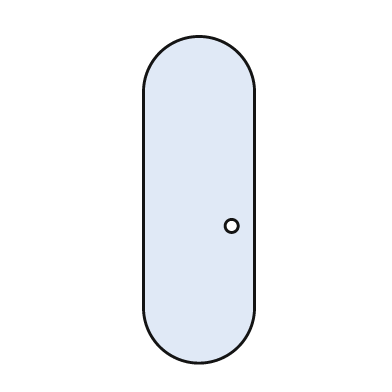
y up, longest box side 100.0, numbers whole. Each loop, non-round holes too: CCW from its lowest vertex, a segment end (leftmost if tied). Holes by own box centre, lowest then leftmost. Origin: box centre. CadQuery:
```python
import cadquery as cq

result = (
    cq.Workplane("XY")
    .moveTo(-17.0, -33.0)
    .threePointArc((0.0, -50.0), (17.0, -33.0))
    .lineTo(17.0, 33.0)
    .threePointArc((0.0, 50.0), (-17.0, 33.0))
    .close()
    .moveTo(10.0, -8.0)
    .circle(2.0)
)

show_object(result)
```